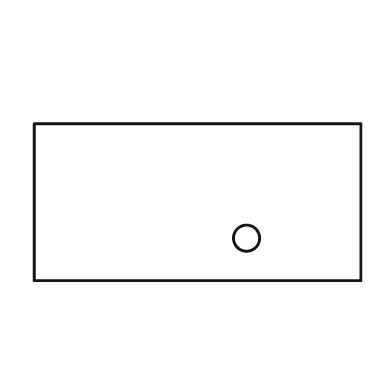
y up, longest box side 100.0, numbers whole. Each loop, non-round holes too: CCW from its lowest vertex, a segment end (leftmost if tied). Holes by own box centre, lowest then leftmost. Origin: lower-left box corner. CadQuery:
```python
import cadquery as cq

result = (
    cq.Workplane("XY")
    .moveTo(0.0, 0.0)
    .lineTo(100.0, 0.0)
    .lineTo(100.0, 48.0)
    .lineTo(0.0, 48.0)
    .close()
    .moveTo(65.0, 13.0)
    .circle(4.0)
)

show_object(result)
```